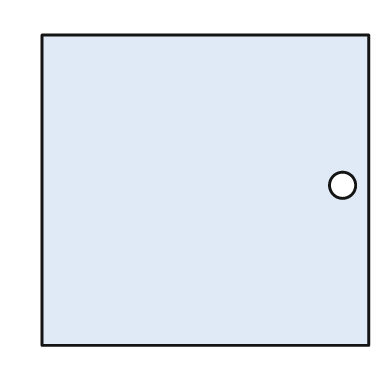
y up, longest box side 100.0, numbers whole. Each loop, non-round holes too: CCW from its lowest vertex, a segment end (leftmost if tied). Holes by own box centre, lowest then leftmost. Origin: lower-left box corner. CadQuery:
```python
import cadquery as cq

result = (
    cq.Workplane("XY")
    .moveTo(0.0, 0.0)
    .lineTo(100.0, 0.0)
    .lineTo(100.0, 95.0)
    .lineTo(0.0, 95.0)
    .close()
    .moveTo(92.0, 49.0)
    .circle(4.0)
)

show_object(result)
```